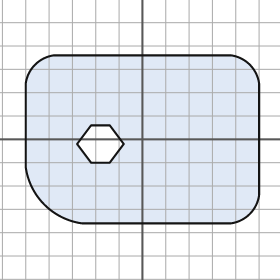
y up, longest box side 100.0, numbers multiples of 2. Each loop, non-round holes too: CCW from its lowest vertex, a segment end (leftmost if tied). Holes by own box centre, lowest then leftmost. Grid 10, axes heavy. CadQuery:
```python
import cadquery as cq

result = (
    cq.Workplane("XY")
    .moveTo(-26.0, -36.0)
    .lineTo(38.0, -36.0)
    .threePointArc((46.0, -32.0), (50.0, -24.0))
    .lineTo(50.0, 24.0)
    .threePointArc((46.0, 32.0), (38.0, 36.0))
    .lineTo(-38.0, 36.0)
    .threePointArc((-46.0, 32.0), (-50.0, 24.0))
    .lineTo(-50.0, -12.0)
    .threePointArc((-42.0, -28.0), (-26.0, -36.0))
    .close()
    .moveTo(-22.0, -10.0)
    .lineTo(-14.0, -10.0)
    .lineTo(-8.0, -2.0)
    .lineTo(-14.0, 6.0)
    .lineTo(-22.0, 6.0)
    .lineTo(-28.0, -2.0)
    .close()
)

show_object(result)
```